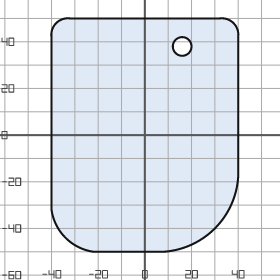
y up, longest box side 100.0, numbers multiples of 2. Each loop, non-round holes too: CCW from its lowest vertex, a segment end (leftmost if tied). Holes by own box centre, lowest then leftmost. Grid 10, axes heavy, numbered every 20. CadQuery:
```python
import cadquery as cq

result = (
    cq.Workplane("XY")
    .moveTo(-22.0, -50.0)
    .lineTo(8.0, -50.0)
    .threePointArc((30.0, -40.0), (40.0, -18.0))
    .lineTo(40.0, 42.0)
    .threePointArc((38.0, 48.0), (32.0, 50.0))
    .lineTo(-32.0, 50.0)
    .threePointArc((-38.0, 48.0), (-40.0, 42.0))
    .lineTo(-40.0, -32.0)
    .threePointArc((-34.0, -44.0), (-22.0, -50.0))
    .close()
    .moveTo(16.0, 38.0)
    .circle(4.0)
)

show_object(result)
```